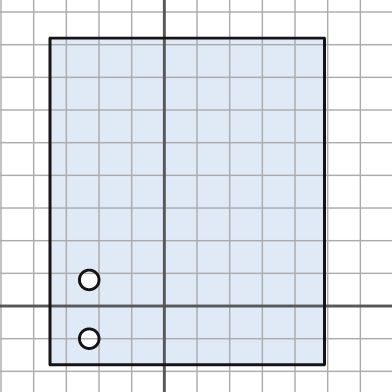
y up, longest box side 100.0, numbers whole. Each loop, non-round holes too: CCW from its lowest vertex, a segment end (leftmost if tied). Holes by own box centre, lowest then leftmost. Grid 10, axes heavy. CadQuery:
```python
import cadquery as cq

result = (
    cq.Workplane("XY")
    .moveTo(-35.0, -18.0)
    .lineTo(49.0, -18.0)
    .lineTo(49.0, 82.0)
    .lineTo(-35.0, 82.0)
    .close()
    .moveTo(-23.0, -10.0)
    .circle(3.0)
    .moveTo(-23.0, 8.0)
    .circle(3.0)
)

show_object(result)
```